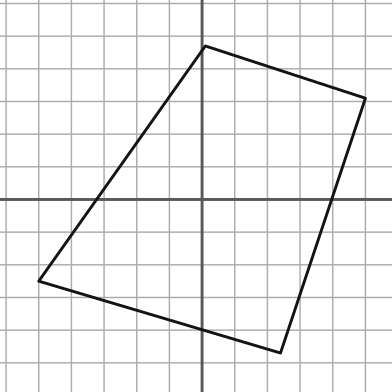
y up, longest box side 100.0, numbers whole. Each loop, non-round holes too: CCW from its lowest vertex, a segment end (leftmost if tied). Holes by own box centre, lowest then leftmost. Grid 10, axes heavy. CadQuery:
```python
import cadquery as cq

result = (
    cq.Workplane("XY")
    .moveTo(24.0, -47.0)
    .lineTo(50.0, 31.0)
    .lineTo(1.0, 47.0)
    .lineTo(-50.0, -25.0)
    .close()
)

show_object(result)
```